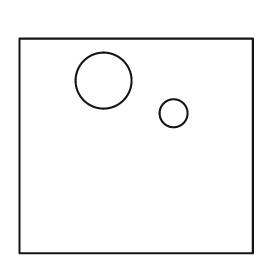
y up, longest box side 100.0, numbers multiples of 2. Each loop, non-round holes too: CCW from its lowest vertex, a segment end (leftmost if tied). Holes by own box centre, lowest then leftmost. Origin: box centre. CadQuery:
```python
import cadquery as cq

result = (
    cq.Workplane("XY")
    .moveTo(-50.0, -46.0)
    .lineTo(50.0, -46.0)
    .lineTo(50.0, 46.0)
    .lineTo(-50.0, 46.0)
    .close()
    .moveTo(16.0, 14.0)
    .circle(6.0)
    .moveTo(-14.0, 28.0)
    .circle(12.0)
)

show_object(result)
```